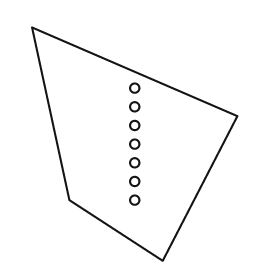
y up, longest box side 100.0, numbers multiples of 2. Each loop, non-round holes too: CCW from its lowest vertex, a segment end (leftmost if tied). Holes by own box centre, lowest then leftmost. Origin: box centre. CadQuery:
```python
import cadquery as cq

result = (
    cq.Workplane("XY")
    .moveTo(12.0, -50.0)
    .lineTo(44.0, 12.0)
    .lineTo(-44.0, 50.0)
    .lineTo(-28.0, -24.0)
    .close()
    .moveTo(0.0, -24.0)
    .circle(2.0)
    .moveTo(0.0, -16.0)
    .circle(2.0)
    .moveTo(0.0, -8.0)
    .circle(2.0)
    .moveTo(0.0, 0.0)
    .circle(2.0)
    .moveTo(0.0, 8.0)
    .circle(2.0)
    .moveTo(0.0, 16.0)
    .circle(2.0)
    .moveTo(0.0, 24.0)
    .circle(2.0)
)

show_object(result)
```